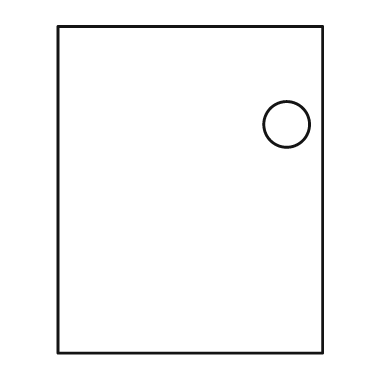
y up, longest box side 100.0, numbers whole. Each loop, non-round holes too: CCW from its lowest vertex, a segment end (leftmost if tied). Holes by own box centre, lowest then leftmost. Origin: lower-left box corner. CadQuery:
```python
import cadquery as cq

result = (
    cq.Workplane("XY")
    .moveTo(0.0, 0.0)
    .lineTo(81.0, 0.0)
    .lineTo(81.0, 100.0)
    .lineTo(0.0, 100.0)
    .close()
    .moveTo(70.0, 70.0)
    .circle(7.0)
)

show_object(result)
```